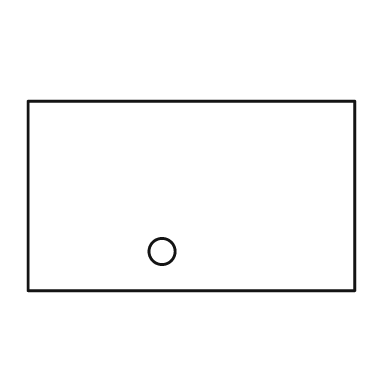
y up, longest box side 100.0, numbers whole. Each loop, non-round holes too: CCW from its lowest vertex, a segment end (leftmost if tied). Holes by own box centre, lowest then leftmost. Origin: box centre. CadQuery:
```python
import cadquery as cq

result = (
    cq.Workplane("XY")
    .moveTo(-50.0, -29.0)
    .lineTo(50.0, -29.0)
    .lineTo(50.0, 29.0)
    .lineTo(-50.0, 29.0)
    .close()
    .moveTo(-9.0, -17.0)
    .circle(4.0)
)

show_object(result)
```